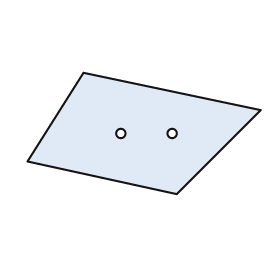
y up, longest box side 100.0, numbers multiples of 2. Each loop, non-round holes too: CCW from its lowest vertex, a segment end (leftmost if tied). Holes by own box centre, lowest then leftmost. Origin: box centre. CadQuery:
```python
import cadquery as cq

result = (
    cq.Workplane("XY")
    .moveTo(14.0, -26.0)
    .lineTo(50.0, 10.0)
    .lineTo(-26.0, 26.0)
    .lineTo(-50.0, -12.0)
    .close()
    .moveTo(-10.0, 0.0)
    .circle(2.0)
    .moveTo(12.0, 0.0)
    .circle(2.0)
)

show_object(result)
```